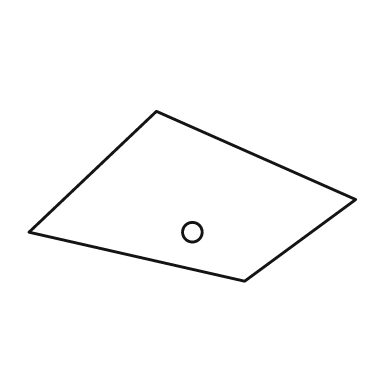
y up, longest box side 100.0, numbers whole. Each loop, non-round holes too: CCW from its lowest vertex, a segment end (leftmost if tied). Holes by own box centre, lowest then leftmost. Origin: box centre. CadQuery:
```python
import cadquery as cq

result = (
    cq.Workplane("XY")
    .moveTo(16.0, -26.0)
    .lineTo(50.0, -1.0)
    .lineTo(-11.0, 26.0)
    .lineTo(-50.0, -11.0)
    .close()
    .moveTo(0.0, -11.0)
    .circle(3.0)
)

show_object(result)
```